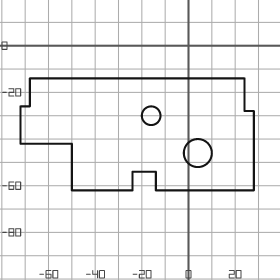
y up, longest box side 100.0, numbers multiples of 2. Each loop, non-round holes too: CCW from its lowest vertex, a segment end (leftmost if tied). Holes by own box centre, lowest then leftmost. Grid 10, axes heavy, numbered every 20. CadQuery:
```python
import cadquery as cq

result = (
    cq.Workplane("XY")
    .moveTo(-50.0, -62.0)
    .lineTo(-24.0, -62.0)
    .lineTo(-24.0, -54.0)
    .lineTo(-14.0, -54.0)
    .lineTo(-14.0, -62.0)
    .lineTo(28.0, -62.0)
    .lineTo(28.0, -28.0)
    .lineTo(24.0, -28.0)
    .lineTo(24.0, -14.0)
    .lineTo(-68.0, -14.0)
    .lineTo(-68.0, -26.0)
    .lineTo(-72.0, -26.0)
    .lineTo(-72.0, -42.0)
    .lineTo(-50.0, -42.0)
    .close()
    .moveTo(4.0, -46.0)
    .circle(6.0)
    .moveTo(-16.0, -30.0)
    .circle(4.0)
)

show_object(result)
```